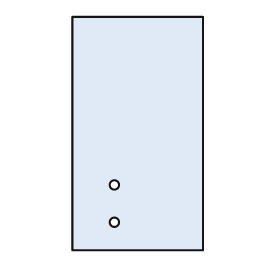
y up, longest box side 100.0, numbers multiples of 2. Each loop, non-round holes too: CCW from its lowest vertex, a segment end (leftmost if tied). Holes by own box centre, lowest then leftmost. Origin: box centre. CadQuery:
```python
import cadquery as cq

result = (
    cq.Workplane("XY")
    .moveTo(-28.0, -50.0)
    .lineTo(28.0, -50.0)
    .lineTo(28.0, 50.0)
    .lineTo(-28.0, 50.0)
    .close()
    .moveTo(-10.0, -38.0)
    .circle(2.0)
    .moveTo(-10.0, -22.0)
    .circle(2.0)
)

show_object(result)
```